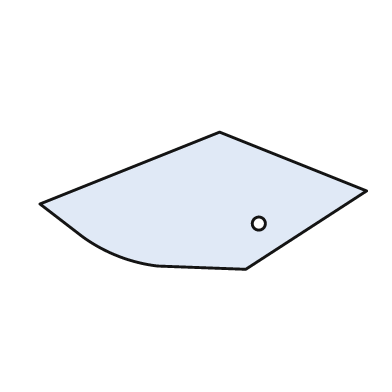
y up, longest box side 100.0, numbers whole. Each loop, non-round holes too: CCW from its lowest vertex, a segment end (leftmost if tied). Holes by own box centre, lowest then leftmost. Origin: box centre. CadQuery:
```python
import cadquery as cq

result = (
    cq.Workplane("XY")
    .moveTo(13.0, -21.0)
    .lineTo(50.0, 3.0)
    .lineTo(5.0, 21.0)
    .lineTo(-50.0, -1.0)
    .lineTo(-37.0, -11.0)
    .threePointArc((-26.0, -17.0), (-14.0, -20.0))
    .close()
    .moveTo(17.0, -7.0)
    .circle(2.0)
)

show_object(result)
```